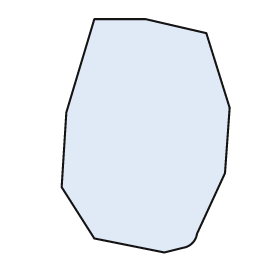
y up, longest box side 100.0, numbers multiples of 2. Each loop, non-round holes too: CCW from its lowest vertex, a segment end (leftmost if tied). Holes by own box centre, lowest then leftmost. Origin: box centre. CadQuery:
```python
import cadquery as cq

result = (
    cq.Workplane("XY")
    .moveTo(8.0, -50.0)
    .lineTo(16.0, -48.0)
    .threePointArc((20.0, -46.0), (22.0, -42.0))
    .lineTo(34.0, -16.0)
    .lineTo(36.0, 12.0)
    .lineTo(26.0, 44.0)
    .lineTo(0.0, 50.0)
    .lineTo(-22.0, 50.0)
    .lineTo(-34.0, 10.0)
    .lineTo(-36.0, -22.0)
    .lineTo(-22.0, -44.0)
    .close()
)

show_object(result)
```